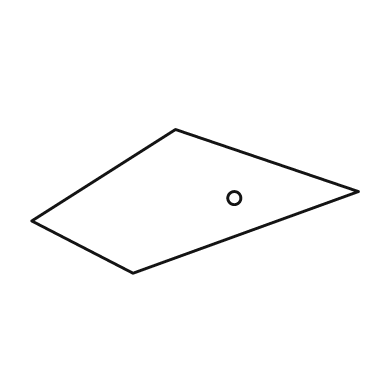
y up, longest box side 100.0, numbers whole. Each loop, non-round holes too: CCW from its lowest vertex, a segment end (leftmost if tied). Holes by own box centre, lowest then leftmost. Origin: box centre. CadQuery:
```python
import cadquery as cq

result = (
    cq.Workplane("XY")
    .moveTo(-19.0, -22.0)
    .lineTo(50.0, 3.0)
    .lineTo(-6.0, 22.0)
    .lineTo(-50.0, -6.0)
    .close()
    .moveTo(12.0, 1.0)
    .circle(2.0)
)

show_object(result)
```